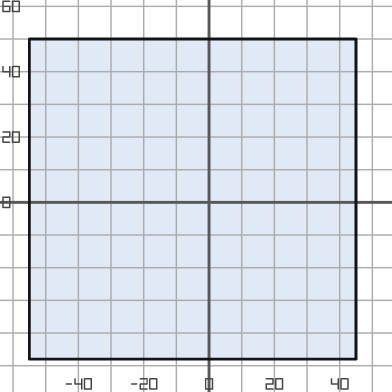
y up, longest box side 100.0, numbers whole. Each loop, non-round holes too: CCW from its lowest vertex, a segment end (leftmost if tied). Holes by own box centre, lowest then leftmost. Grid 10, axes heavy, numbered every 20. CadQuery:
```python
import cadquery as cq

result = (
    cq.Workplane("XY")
    .moveTo(-55.0, -48.0)
    .lineTo(45.0, -48.0)
    .lineTo(45.0, 50.0)
    .lineTo(-55.0, 50.0)
    .close()
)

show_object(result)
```